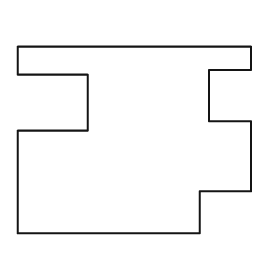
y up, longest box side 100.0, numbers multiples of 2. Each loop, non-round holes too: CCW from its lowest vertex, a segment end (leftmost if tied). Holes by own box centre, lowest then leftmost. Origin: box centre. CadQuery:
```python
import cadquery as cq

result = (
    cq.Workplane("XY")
    .moveTo(-50.0, -40.0)
    .lineTo(28.0, -40.0)
    .lineTo(28.0, -22.0)
    .lineTo(50.0, -22.0)
    .lineTo(50.0, 8.0)
    .lineTo(32.0, 8.0)
    .lineTo(32.0, 30.0)
    .lineTo(50.0, 30.0)
    .lineTo(50.0, 40.0)
    .lineTo(-50.0, 40.0)
    .lineTo(-50.0, 28.0)
    .lineTo(-20.0, 28.0)
    .lineTo(-20.0, 4.0)
    .lineTo(-50.0, 4.0)
    .close()
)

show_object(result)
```